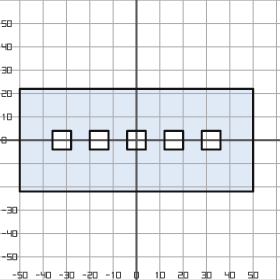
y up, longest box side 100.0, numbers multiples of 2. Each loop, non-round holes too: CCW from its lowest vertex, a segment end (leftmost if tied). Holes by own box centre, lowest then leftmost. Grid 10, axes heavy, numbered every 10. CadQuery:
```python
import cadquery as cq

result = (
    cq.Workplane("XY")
    .moveTo(-50.0, -22.0)
    .lineTo(50.0, -22.0)
    .lineTo(50.0, 22.0)
    .lineTo(-50.0, 22.0)
    .close()
    .moveTo(-36.0, -4.0)
    .lineTo(-28.0, -4.0)
    .lineTo(-28.0, 4.0)
    .lineTo(-36.0, 4.0)
    .close()
    .moveTo(-20.0, -4.0)
    .lineTo(-12.0, -4.0)
    .lineTo(-12.0, 4.0)
    .lineTo(-20.0, 4.0)
    .close()
    .moveTo(-4.0, -4.0)
    .lineTo(4.0, -4.0)
    .lineTo(4.0, 4.0)
    .lineTo(-4.0, 4.0)
    .close()
    .moveTo(12.0, -4.0)
    .lineTo(20.0, -4.0)
    .lineTo(20.0, 4.0)
    .lineTo(12.0, 4.0)
    .close()
    .moveTo(28.0, -4.0)
    .lineTo(36.0, -4.0)
    .lineTo(36.0, 4.0)
    .lineTo(28.0, 4.0)
    .close()
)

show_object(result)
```